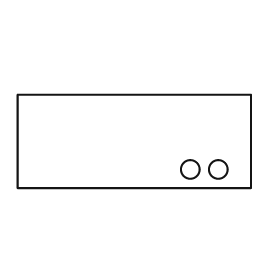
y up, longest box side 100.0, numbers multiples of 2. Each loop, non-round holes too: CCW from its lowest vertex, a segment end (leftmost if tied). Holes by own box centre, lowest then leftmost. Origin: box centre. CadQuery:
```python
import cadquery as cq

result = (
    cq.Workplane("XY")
    .moveTo(-50.0, -20.0)
    .lineTo(50.0, -20.0)
    .lineTo(50.0, 20.0)
    .lineTo(-50.0, 20.0)
    .close()
    .moveTo(24.0, -12.0)
    .circle(4.0)
    .moveTo(36.0, -12.0)
    .circle(4.0)
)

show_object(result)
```